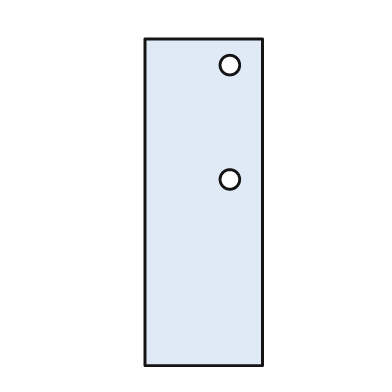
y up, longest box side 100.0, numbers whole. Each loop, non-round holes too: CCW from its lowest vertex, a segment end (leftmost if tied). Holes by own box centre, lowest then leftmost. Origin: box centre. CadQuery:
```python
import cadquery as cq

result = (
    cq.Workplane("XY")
    .moveTo(-18.0, -50.0)
    .lineTo(18.0, -50.0)
    .lineTo(18.0, 50.0)
    .lineTo(-18.0, 50.0)
    .close()
    .moveTo(8.0, 7.0)
    .circle(3.0)
    .moveTo(8.0, 42.0)
    .circle(3.0)
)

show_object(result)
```